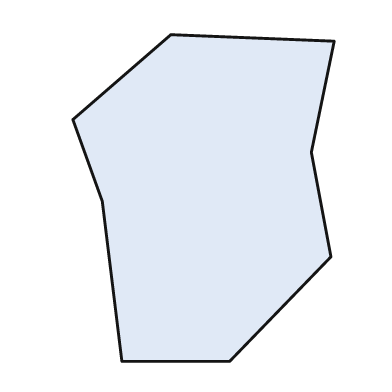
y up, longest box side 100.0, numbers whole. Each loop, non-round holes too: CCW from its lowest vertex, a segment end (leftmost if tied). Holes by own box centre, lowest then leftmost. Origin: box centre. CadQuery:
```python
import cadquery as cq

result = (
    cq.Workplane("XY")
    .moveTo(-25.0, -50.0)
    .lineTo(8.0, -50.0)
    .lineTo(39.0, -18.0)
    .lineTo(33.0, 14.0)
    .lineTo(40.0, 48.0)
    .lineTo(-10.0, 50.0)
    .lineTo(-40.0, 24.0)
    .lineTo(-31.0, -1.0)
    .close()
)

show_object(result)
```